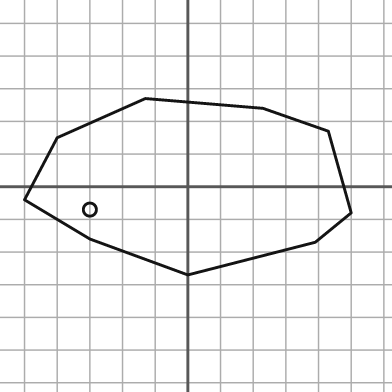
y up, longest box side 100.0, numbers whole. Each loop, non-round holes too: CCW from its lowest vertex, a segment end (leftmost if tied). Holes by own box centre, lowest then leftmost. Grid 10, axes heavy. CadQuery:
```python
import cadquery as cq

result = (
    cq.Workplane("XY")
    .moveTo(0.0, -27.0)
    .lineTo(39.0, -17.0)
    .lineTo(50.0, -8.0)
    .lineTo(43.0, 17.0)
    .lineTo(23.0, 24.0)
    .lineTo(-13.0, 27.0)
    .lineTo(-40.0, 15.0)
    .lineTo(-50.0, -4.0)
    .lineTo(-30.0, -16.0)
    .close()
    .moveTo(-30.0, -7.0)
    .circle(2.0)
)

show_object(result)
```